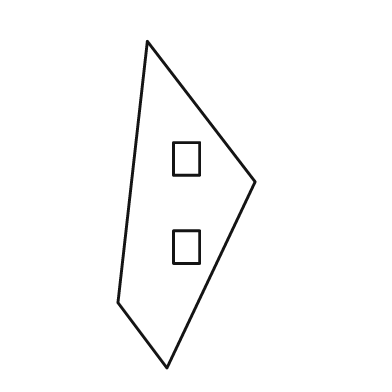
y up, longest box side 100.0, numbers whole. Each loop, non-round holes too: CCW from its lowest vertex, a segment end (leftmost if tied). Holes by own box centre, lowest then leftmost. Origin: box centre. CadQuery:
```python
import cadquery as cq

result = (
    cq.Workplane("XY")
    .moveTo(-6.0, -50.0)
    .lineTo(21.0, 7.0)
    .lineTo(-12.0, 50.0)
    .lineTo(-21.0, -30.0)
    .close()
    .moveTo(-4.0, -18.0)
    .lineTo(4.0, -18.0)
    .lineTo(4.0, -8.0)
    .lineTo(-4.0, -8.0)
    .close()
    .moveTo(-4.0, 9.0)
    .lineTo(4.0, 9.0)
    .lineTo(4.0, 19.0)
    .lineTo(-4.0, 19.0)
    .close()
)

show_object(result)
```